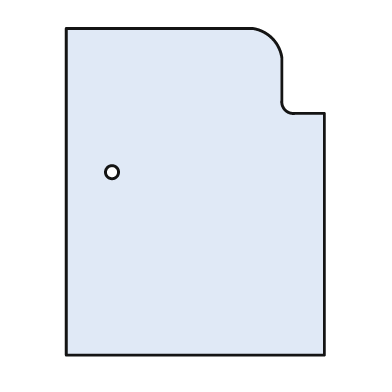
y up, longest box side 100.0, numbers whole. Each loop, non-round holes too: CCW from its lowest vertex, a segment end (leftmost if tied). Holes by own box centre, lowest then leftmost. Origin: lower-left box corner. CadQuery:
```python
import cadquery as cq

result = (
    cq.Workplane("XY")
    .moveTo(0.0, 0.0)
    .lineTo(79.0, 0.0)
    .lineTo(79.0, 74.0)
    .lineTo(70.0, 74.0)
    .threePointArc((67.0, 75.0), (66.0, 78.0))
    .lineTo(66.0, 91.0)
    .threePointArc((63.0, 97.0), (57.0, 100.0))
    .lineTo(0.0, 100.0)
    .close()
    .moveTo(14.0, 56.0)
    .circle(2.0)
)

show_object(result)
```